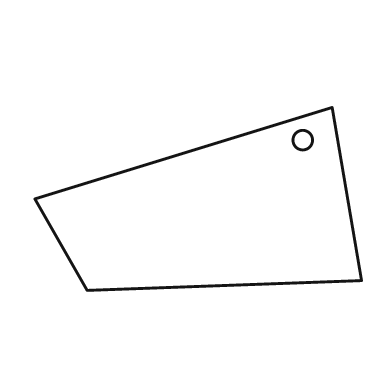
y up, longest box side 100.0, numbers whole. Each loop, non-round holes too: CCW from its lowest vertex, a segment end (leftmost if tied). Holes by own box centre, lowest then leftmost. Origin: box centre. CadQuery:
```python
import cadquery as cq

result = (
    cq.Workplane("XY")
    .moveTo(-34.0, -28.0)
    .lineTo(50.0, -25.0)
    .lineTo(41.0, 28.0)
    .lineTo(-50.0, 0.0)
    .close()
    .moveTo(32.0, 18.0)
    .circle(3.0)
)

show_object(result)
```